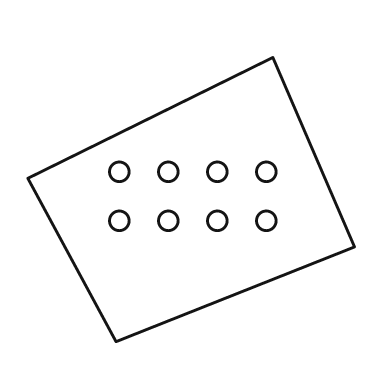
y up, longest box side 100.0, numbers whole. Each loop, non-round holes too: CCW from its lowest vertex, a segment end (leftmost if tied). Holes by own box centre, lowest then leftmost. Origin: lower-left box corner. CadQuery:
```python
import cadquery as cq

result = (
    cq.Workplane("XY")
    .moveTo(27.0, 0.0)
    .lineTo(100.0, 29.0)
    .lineTo(75.0, 87.0)
    .lineTo(0.0, 50.0)
    .close()
    .moveTo(28.0, 37.0)
    .circle(3.0)
    .moveTo(43.0, 37.0)
    .circle(3.0)
    .moveTo(58.0, 37.0)
    .circle(3.0)
    .moveTo(73.0, 37.0)
    .circle(3.0)
    .moveTo(28.0, 52.0)
    .circle(3.0)
    .moveTo(43.0, 52.0)
    .circle(3.0)
    .moveTo(58.0, 52.0)
    .circle(3.0)
    .moveTo(73.0, 52.0)
    .circle(3.0)
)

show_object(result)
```